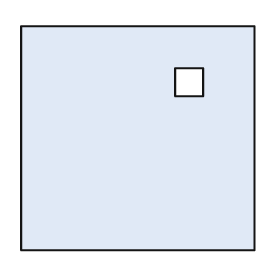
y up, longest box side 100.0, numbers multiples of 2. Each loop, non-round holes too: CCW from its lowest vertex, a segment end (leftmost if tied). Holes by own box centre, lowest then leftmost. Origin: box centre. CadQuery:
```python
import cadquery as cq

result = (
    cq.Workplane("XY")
    .moveTo(-50.0, -48.0)
    .lineTo(50.0, -48.0)
    .lineTo(50.0, 48.0)
    .lineTo(-50.0, 48.0)
    .close()
    .moveTo(16.0, 18.0)
    .lineTo(28.0, 18.0)
    .lineTo(28.0, 30.0)
    .lineTo(16.0, 30.0)
    .close()
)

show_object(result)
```